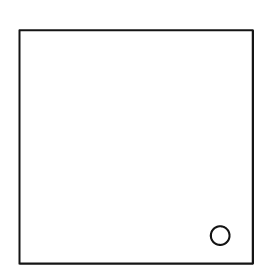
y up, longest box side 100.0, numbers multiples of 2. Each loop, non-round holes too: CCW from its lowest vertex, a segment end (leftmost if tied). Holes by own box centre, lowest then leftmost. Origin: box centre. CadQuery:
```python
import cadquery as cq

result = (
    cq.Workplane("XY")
    .moveTo(-50.0, -50.0)
    .lineTo(50.0, -50.0)
    .lineTo(50.0, 50.0)
    .lineTo(-50.0, 50.0)
    .close()
    .moveTo(36.0, -38.0)
    .circle(4.0)
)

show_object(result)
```